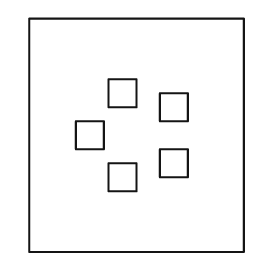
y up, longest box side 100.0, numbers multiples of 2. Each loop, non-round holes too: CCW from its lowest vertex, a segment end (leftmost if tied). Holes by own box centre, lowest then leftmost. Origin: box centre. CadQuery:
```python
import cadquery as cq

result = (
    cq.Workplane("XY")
    .moveTo(-46.0, -50.0)
    .lineTo(46.0, -50.0)
    .lineTo(46.0, 50.0)
    .lineTo(-46.0, 50.0)
    .close()
    .moveTo(-12.0, -24.0)
    .lineTo(0.0, -24.0)
    .lineTo(0.0, -12.0)
    .lineTo(-12.0, -12.0)
    .close()
    .moveTo(10.0, -18.0)
    .lineTo(22.0, -18.0)
    .lineTo(22.0, -6.0)
    .lineTo(10.0, -6.0)
    .close()
    .moveTo(-26.0, -6.0)
    .lineTo(-14.0, -6.0)
    .lineTo(-14.0, 6.0)
    .lineTo(-26.0, 6.0)
    .close()
    .moveTo(10.0, 6.0)
    .lineTo(22.0, 6.0)
    .lineTo(22.0, 18.0)
    .lineTo(10.0, 18.0)
    .close()
    .moveTo(-12.0, 12.0)
    .lineTo(0.0, 12.0)
    .lineTo(0.0, 24.0)
    .lineTo(-12.0, 24.0)
    .close()
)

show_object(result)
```